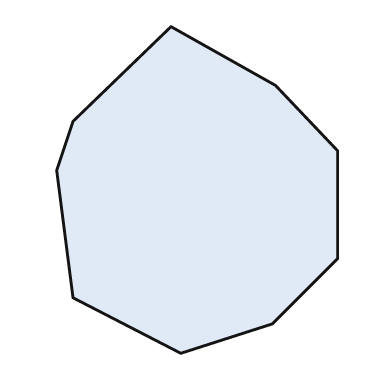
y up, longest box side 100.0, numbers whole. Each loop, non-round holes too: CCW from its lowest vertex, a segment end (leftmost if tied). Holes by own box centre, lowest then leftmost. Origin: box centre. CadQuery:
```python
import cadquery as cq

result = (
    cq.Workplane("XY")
    .moveTo(-5.0, -50.0)
    .lineTo(23.0, -41.0)
    .lineTo(43.0, -21.0)
    .lineTo(43.0, 12.0)
    .lineTo(24.0, 32.0)
    .lineTo(-8.0, 50.0)
    .lineTo(-38.0, 21.0)
    .lineTo(-43.0, 6.0)
    .lineTo(-38.0, -33.0)
    .close()
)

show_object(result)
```